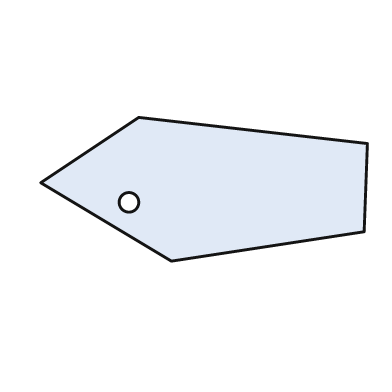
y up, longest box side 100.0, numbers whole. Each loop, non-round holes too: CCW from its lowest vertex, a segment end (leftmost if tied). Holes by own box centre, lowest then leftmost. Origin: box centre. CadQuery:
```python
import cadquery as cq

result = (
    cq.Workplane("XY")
    .moveTo(-10.0, -22.0)
    .lineTo(49.0, -13.0)
    .lineTo(50.0, 14.0)
    .lineTo(-20.0, 22.0)
    .lineTo(-50.0, 2.0)
    .close()
    .moveTo(-23.0, -4.0)
    .circle(3.0)
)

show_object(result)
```